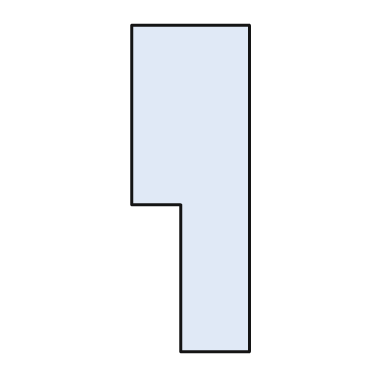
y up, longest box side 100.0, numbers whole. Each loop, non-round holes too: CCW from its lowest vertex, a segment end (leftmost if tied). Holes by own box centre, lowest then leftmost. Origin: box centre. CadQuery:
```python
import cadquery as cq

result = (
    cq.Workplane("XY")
    .moveTo(-3.0, -50.0)
    .lineTo(18.0, -50.0)
    .lineTo(18.0, 50.0)
    .lineTo(-18.0, 50.0)
    .lineTo(-18.0, -5.0)
    .lineTo(-3.0, -5.0)
    .close()
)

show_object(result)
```